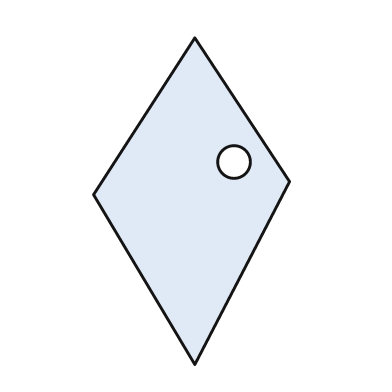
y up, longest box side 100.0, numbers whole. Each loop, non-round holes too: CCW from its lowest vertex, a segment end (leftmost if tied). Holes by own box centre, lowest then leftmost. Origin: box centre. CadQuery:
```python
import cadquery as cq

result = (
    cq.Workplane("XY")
    .moveTo(1.0, -50.0)
    .lineTo(30.0, 6.0)
    .lineTo(1.0, 50.0)
    .lineTo(-30.0, 2.0)
    .close()
    .moveTo(13.0, 12.0)
    .circle(5.0)
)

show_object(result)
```